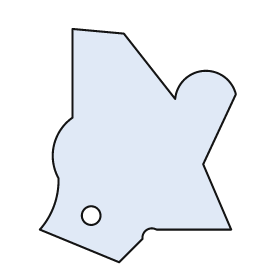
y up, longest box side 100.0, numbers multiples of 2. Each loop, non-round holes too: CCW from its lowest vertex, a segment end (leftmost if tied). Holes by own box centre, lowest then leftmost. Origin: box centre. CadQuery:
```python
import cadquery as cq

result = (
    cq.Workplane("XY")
    .moveTo(-8.0, -50.0)
    .lineTo(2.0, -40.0)
    .threePointArc((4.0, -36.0), (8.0, -36.0))
    .lineTo(40.0, -36.0)
    .lineTo(28.0, -8.0)
    .lineTo(42.0, 22.0)
    .threePointArc((28.0, 32.0), (16.0, 20.0))
    .lineTo(-6.0, 48.0)
    .lineTo(-28.0, 50.0)
    .lineTo(-28.0, 12.0)
    .threePointArc((-36.0, 0.0), (-34.0, -14.0))
    .threePointArc((-36.0, -26.0), (-42.0, -36.0))
    .close()
    .moveTo(-20.0, -30.0)
    .circle(4.0)
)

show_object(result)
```